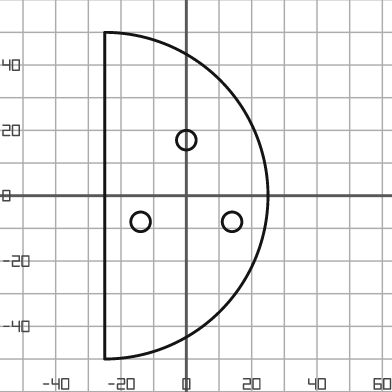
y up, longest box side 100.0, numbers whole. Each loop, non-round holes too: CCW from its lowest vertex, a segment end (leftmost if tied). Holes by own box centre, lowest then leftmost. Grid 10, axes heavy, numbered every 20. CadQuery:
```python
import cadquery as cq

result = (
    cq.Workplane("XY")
    .moveTo(-25.0, -50.0)
    .threePointArc((25.0, 0.0), (-25.0, 50.0))
    .close()
    .moveTo(-14.0, -8.0)
    .circle(3.0)
    .moveTo(14.0, -8.0)
    .circle(3.0)
    .moveTo(0.0, 17.0)
    .circle(3.0)
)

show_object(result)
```